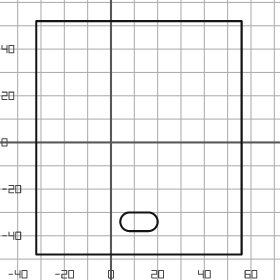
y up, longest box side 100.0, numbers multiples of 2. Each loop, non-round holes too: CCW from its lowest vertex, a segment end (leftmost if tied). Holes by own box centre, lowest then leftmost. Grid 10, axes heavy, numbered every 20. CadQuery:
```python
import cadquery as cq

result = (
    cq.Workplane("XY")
    .moveTo(-32.0, -48.0)
    .lineTo(56.0, -48.0)
    .lineTo(56.0, 52.0)
    .lineTo(-32.0, 52.0)
    .close()
    .moveTo(8.0, -38.0)
    .lineTo(16.0, -38.0)
    .threePointArc((20.0, -34.0), (16.0, -30.0))
    .lineTo(8.0, -30.0)
    .threePointArc((4.0, -34.0), (8.0, -38.0))
    .close()
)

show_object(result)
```